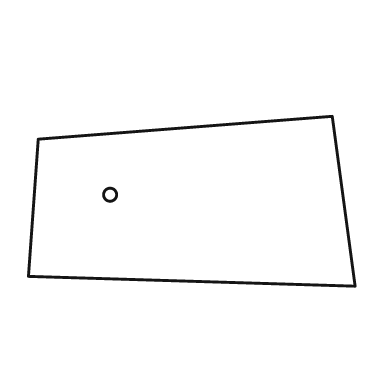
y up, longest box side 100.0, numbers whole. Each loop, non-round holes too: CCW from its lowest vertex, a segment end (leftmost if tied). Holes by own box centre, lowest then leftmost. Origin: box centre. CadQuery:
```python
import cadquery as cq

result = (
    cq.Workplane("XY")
    .moveTo(50.0, -26.0)
    .lineTo(43.0, 26.0)
    .lineTo(-47.0, 19.0)
    .lineTo(-50.0, -23.0)
    .close()
    .moveTo(-25.0, 2.0)
    .circle(2.0)
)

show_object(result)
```